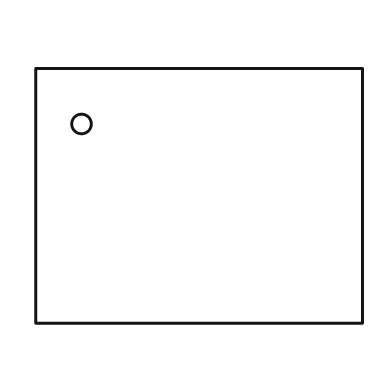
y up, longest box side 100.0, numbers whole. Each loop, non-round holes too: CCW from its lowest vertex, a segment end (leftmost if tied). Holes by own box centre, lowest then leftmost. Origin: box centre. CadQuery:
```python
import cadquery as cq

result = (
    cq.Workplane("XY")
    .moveTo(-50.0, -39.0)
    .lineTo(50.0, -39.0)
    .lineTo(50.0, 39.0)
    .lineTo(-50.0, 39.0)
    .close()
    .moveTo(-36.0, 22.0)
    .circle(3.0)
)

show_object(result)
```